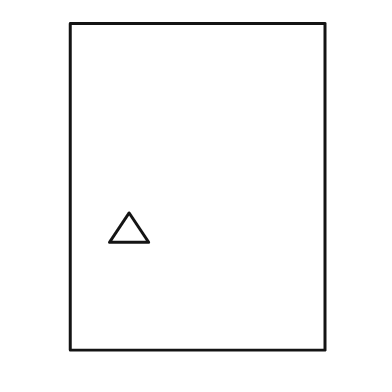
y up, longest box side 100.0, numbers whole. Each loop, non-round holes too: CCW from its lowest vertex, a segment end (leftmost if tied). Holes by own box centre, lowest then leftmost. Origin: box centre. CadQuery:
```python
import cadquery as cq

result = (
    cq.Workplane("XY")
    .moveTo(-39.0, -50.0)
    .lineTo(39.0, -50.0)
    .lineTo(39.0, 50.0)
    .lineTo(-39.0, 50.0)
    .close()
    .moveTo(-27.0, -17.0)
    .lineTo(-15.0, -17.0)
    .lineTo(-21.0, -8.0)
    .close()
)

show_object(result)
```